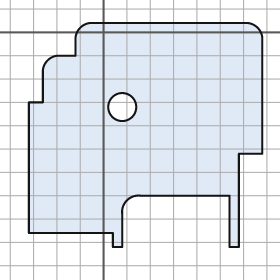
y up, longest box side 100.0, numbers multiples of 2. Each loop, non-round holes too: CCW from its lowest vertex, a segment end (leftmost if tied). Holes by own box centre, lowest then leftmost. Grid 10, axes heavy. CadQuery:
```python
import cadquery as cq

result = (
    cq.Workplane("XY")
    .moveTo(4.0, -92.0)
    .lineTo(8.0, -92.0)
    .lineTo(8.0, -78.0)
    .threePointArc((10.0, -72.0), (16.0, -70.0))
    .lineTo(54.0, -70.0)
    .lineTo(54.0, -92.0)
    .lineTo(58.0, -92.0)
    .lineTo(58.0, -52.0)
    .lineTo(68.0, -52.0)
    .lineTo(68.0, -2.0)
    .threePointArc((66.0, 2.0), (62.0, 4.0))
    .lineTo(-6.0, 4.0)
    .threePointArc((-10.0, 2.0), (-12.0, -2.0))
    .lineTo(-12.0, -10.0)
    .lineTo(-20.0, -10.0)
    .threePointArc((-24.0, -12.0), (-26.0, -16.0))
    .lineTo(-26.0, -30.0)
    .lineTo(-32.0, -30.0)
    .lineTo(-32.0, -86.0)
    .lineTo(4.0, -86.0)
    .close()
    .moveTo(8.0, -32.0)
    .circle(6.0)
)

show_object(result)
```